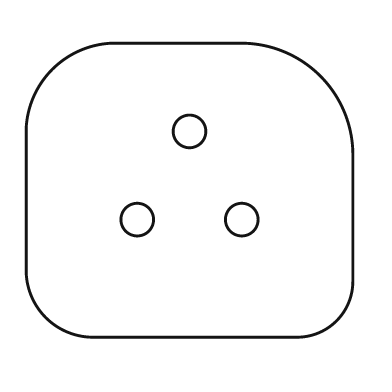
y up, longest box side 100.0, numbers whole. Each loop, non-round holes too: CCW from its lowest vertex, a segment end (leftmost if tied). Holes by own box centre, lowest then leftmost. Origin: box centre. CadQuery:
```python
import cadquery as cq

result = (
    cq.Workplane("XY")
    .moveTo(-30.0, -45.0)
    .lineTo(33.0, -45.0)
    .threePointArc((45.0, -40.0), (50.0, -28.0))
    .lineTo(50.0, 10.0)
    .threePointArc((40.0, 35.0), (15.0, 45.0))
    .lineTo(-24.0, 45.0)
    .threePointArc((-42.0, 37.0), (-50.0, 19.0))
    .lineTo(-50.0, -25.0)
    .threePointArc((-44.0, -39.0), (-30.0, -45.0))
    .close()
    .moveTo(-16.0, -9.0)
    .circle(5.0)
    .moveTo(16.0, -9.0)
    .circle(5.0)
    .moveTo(0.0, 18.0)
    .circle(5.0)
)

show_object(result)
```